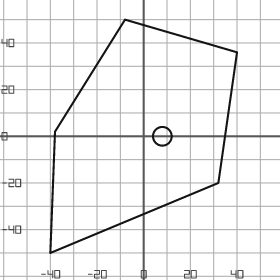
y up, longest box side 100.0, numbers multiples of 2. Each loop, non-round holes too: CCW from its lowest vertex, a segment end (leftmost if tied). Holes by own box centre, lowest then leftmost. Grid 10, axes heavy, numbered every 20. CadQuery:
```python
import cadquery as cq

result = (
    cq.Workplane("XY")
    .moveTo(-40.0, -50.0)
    .lineTo(32.0, -20.0)
    .lineTo(40.0, 36.0)
    .lineTo(-8.0, 50.0)
    .lineTo(-38.0, 2.0)
    .close()
    .moveTo(8.0, 0.0)
    .circle(4.0)
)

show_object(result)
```